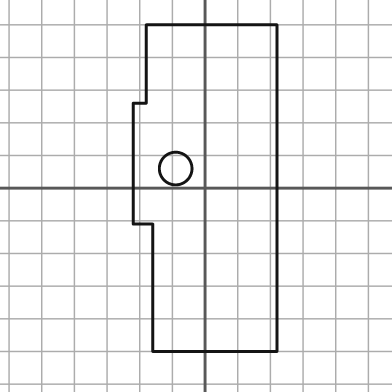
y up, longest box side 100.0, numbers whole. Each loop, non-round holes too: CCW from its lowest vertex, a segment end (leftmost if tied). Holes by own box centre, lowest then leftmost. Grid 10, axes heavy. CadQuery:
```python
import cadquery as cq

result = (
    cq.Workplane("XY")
    .moveTo(-16.0, -50.0)
    .lineTo(22.0, -50.0)
    .lineTo(22.0, 50.0)
    .lineTo(-18.0, 50.0)
    .lineTo(-18.0, 26.0)
    .lineTo(-22.0, 26.0)
    .lineTo(-22.0, -11.0)
    .lineTo(-16.0, -11.0)
    .close()
    .moveTo(-9.0, 6.0)
    .circle(5.0)
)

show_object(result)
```